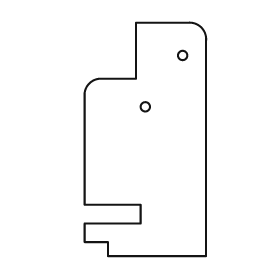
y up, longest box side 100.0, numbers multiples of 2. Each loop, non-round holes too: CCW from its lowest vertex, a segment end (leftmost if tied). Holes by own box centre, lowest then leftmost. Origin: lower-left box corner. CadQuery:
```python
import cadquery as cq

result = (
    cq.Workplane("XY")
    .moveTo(10.0, 0.0)
    .lineTo(52.0, 0.0)
    .lineTo(52.0, 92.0)
    .threePointArc((50.0, 98.0), (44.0, 100.0))
    .lineTo(22.0, 100.0)
    .lineTo(22.0, 76.0)
    .lineTo(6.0, 76.0)
    .threePointArc((2.0, 74.0), (0.0, 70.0))
    .lineTo(0.0, 22.0)
    .lineTo(24.0, 22.0)
    .lineTo(24.0, 14.0)
    .lineTo(0.0, 14.0)
    .lineTo(0.0, 6.0)
    .lineTo(10.0, 6.0)
    .close()
    .moveTo(26.0, 64.0)
    .circle(2.0)
    .moveTo(42.0, 86.0)
    .circle(2.0)
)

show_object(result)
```